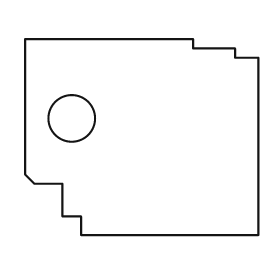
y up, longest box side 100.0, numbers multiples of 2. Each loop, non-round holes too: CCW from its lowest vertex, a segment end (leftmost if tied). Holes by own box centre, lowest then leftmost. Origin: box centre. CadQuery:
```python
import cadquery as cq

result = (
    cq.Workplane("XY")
    .moveTo(-26.0, -42.0)
    .lineTo(50.0, -42.0)
    .lineTo(50.0, 34.0)
    .lineTo(40.0, 34.0)
    .lineTo(40.0, 38.0)
    .lineTo(22.0, 38.0)
    .lineTo(22.0, 42.0)
    .lineTo(-50.0, 42.0)
    .lineTo(-50.0, -16.0)
    .lineTo(-46.0, -20.0)
    .lineTo(-34.0, -20.0)
    .lineTo(-34.0, -34.0)
    .lineTo(-26.0, -34.0)
    .close()
    .moveTo(-30.0, 8.0)
    .circle(10.0)
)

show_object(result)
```